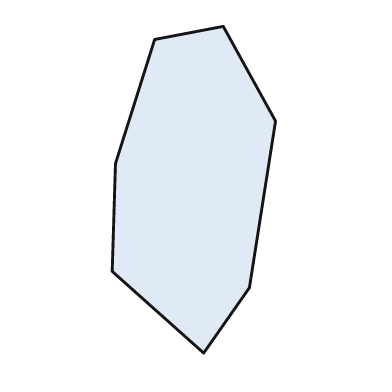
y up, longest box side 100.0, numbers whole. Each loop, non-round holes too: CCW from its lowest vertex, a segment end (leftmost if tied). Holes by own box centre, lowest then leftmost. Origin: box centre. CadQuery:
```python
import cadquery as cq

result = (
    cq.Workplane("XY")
    .moveTo(3.0, -50.0)
    .lineTo(17.0, -30.0)
    .lineTo(25.0, 21.0)
    .lineTo(9.0, 50.0)
    .lineTo(-12.0, 46.0)
    .lineTo(-24.0, 8.0)
    .lineTo(-25.0, -25.0)
    .close()
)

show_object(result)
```